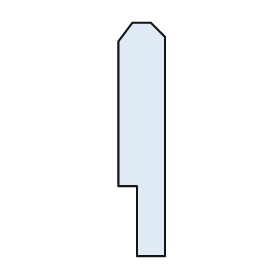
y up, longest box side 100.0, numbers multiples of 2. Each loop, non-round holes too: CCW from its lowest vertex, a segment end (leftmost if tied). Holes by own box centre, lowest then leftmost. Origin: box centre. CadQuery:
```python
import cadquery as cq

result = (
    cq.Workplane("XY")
    .moveTo(-2.0, -50.0)
    .lineTo(10.0, -50.0)
    .lineTo(10.0, 44.0)
    .lineTo(4.0, 50.0)
    .lineTo(-4.0, 50.0)
    .lineTo(-10.0, 42.0)
    .lineTo(-10.0, -20.0)
    .lineTo(-2.0, -20.0)
    .close()
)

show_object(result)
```